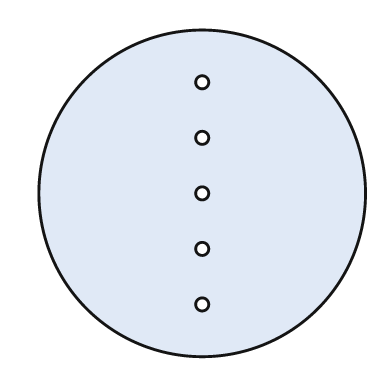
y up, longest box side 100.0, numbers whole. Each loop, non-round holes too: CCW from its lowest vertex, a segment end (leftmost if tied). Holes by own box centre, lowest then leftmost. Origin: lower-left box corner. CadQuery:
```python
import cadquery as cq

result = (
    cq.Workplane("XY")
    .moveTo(50.0, 50.0)
    .circle(50.0)
    .moveTo(50.0, 16.0)
    .circle(2.0)
    .moveTo(50.0, 33.0)
    .circle(2.0)
    .moveTo(50.0, 50.0)
    .circle(2.0)
    .moveTo(50.0, 67.0)
    .circle(2.0)
    .moveTo(50.0, 84.0)
    .circle(2.0)
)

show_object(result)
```